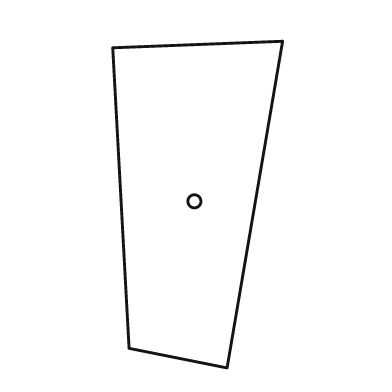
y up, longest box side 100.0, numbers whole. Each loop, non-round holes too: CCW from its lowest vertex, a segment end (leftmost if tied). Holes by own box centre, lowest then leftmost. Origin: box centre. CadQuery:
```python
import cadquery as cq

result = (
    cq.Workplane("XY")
    .moveTo(9.0, -50.0)
    .lineTo(26.0, 50.0)
    .lineTo(-26.0, 48.0)
    .lineTo(-21.0, -44.0)
    .close()
    .moveTo(-1.0, 1.0)
    .circle(2.0)
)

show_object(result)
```